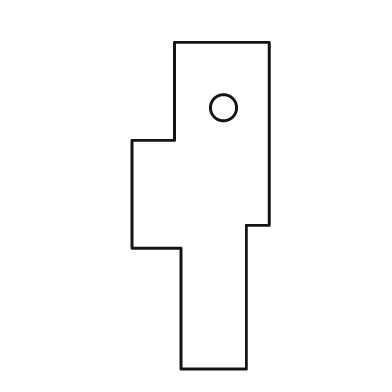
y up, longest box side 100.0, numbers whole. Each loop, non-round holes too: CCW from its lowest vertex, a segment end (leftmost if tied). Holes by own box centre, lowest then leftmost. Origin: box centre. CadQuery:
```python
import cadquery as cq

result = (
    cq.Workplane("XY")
    .moveTo(-6.0, -50.0)
    .lineTo(14.0, -50.0)
    .lineTo(14.0, -6.0)
    .lineTo(21.0, -6.0)
    .lineTo(21.0, 50.0)
    .lineTo(-8.0, 50.0)
    .lineTo(-8.0, 20.0)
    .lineTo(-21.0, 20.0)
    .lineTo(-21.0, -13.0)
    .lineTo(-6.0, -13.0)
    .close()
    .moveTo(7.0, 30.0)
    .circle(4.0)
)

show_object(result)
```